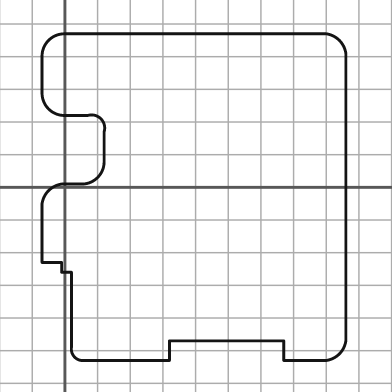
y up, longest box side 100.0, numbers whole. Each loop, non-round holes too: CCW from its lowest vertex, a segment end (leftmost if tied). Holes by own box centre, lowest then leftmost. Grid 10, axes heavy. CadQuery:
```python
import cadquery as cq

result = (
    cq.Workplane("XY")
    .moveTo(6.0, -53.0)
    .lineTo(32.0, -53.0)
    .lineTo(32.0, -47.0)
    .lineTo(67.0, -47.0)
    .lineTo(67.0, -53.0)
    .lineTo(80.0, -53.0)
    .threePointArc((84.0, -51.0), (86.0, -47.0))
    .lineTo(86.0, 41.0)
    .threePointArc((84.0, 45.0), (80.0, 47.0))
    .lineTo(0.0, 47.0)
    .threePointArc((-5.0, 45.0), (-7.0, 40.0))
    .lineTo(-7.0, 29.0)
    .threePointArc((-5.0, 24.0), (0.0, 22.0))
    .lineTo(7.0, 22.0)
    .threePointArc((11.0, 21.0), (12.0, 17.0))
    .lineTo(12.0, 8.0)
    .threePointArc((10.0, 3.0), (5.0, 1.0))
    .lineTo(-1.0, 1.0)
    .threePointArc((-5.0, -1.0), (-7.0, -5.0))
    .lineTo(-7.0, -23.0)
    .lineTo(-1.0, -23.0)
    .lineTo(-1.0, -26.0)
    .lineTo(2.0, -26.0)
    .lineTo(2.0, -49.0)
    .threePointArc((3.0, -52.0), (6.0, -53.0))
    .close()
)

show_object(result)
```